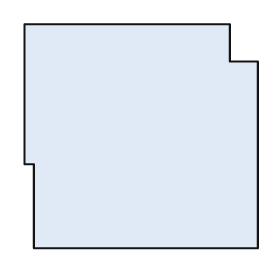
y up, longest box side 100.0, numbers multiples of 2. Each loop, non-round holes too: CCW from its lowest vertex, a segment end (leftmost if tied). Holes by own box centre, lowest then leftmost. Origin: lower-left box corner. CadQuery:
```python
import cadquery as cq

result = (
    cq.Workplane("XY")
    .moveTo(4.0, 0.0)
    .lineTo(100.0, 0.0)
    .lineTo(100.0, 80.0)
    .lineTo(88.0, 80.0)
    .lineTo(88.0, 96.0)
    .lineTo(0.0, 96.0)
    .lineTo(0.0, 36.0)
    .lineTo(4.0, 36.0)
    .close()
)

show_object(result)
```